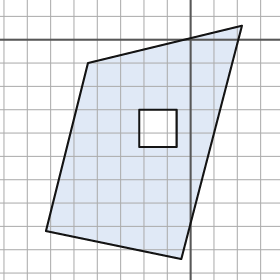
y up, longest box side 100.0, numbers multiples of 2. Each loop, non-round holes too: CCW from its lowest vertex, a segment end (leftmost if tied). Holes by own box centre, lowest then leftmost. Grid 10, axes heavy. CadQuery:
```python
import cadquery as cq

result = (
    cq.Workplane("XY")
    .moveTo(-4.0, -94.0)
    .lineTo(22.0, 6.0)
    .lineTo(-44.0, -10.0)
    .lineTo(-62.0, -82.0)
    .close()
    .moveTo(-22.0, -46.0)
    .lineTo(-6.0, -46.0)
    .lineTo(-6.0, -30.0)
    .lineTo(-22.0, -30.0)
    .close()
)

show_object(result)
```